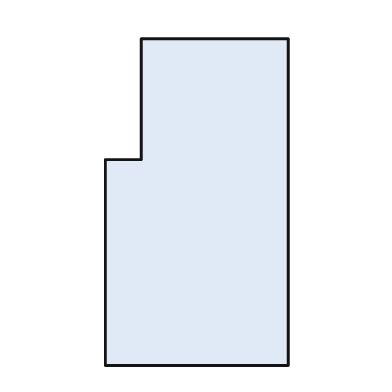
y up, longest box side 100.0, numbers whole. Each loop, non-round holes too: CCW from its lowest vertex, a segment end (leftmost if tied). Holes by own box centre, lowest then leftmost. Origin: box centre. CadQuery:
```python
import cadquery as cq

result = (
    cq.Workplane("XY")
    .moveTo(-28.0, -50.0)
    .lineTo(28.0, -50.0)
    .lineTo(28.0, 50.0)
    .lineTo(-17.0, 50.0)
    .lineTo(-17.0, 13.0)
    .lineTo(-28.0, 13.0)
    .close()
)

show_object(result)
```